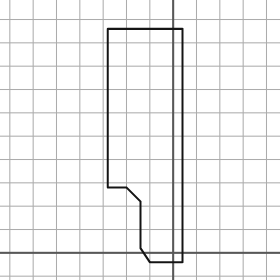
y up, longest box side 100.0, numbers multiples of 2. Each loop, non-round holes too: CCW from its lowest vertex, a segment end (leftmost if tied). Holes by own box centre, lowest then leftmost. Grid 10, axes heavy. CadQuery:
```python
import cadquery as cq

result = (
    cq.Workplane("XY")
    .moveTo(-10.0, -4.0)
    .lineTo(4.0, -4.0)
    .lineTo(4.0, 96.0)
    .lineTo(-28.0, 96.0)
    .lineTo(-28.0, 28.0)
    .lineTo(-20.0, 28.0)
    .lineTo(-14.0, 22.0)
    .lineTo(-14.0, 2.0)
    .close()
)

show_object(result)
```